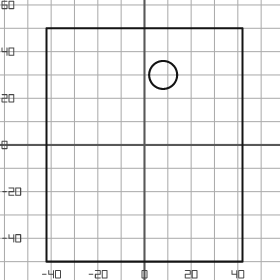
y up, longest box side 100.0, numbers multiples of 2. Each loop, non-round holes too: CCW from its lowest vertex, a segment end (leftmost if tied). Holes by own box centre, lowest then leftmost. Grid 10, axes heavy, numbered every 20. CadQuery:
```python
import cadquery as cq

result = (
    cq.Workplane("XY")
    .moveTo(-42.0, -50.0)
    .lineTo(42.0, -50.0)
    .lineTo(42.0, 50.0)
    .lineTo(-42.0, 50.0)
    .close()
    .moveTo(8.0, 30.0)
    .circle(6.0)
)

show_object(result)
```